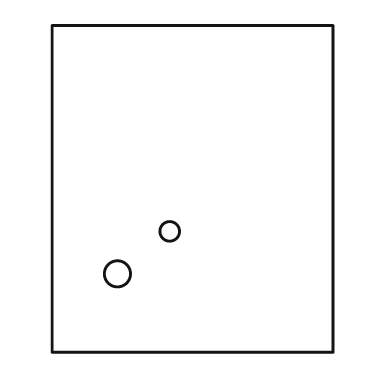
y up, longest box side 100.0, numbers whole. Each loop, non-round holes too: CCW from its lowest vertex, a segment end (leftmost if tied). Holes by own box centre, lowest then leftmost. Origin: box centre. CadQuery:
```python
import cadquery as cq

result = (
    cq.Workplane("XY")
    .moveTo(-43.0, -50.0)
    .lineTo(43.0, -50.0)
    .lineTo(43.0, 50.0)
    .lineTo(-43.0, 50.0)
    .close()
    .moveTo(-23.0, -26.0)
    .circle(4.0)
    .moveTo(-7.0, -13.0)
    .circle(3.0)
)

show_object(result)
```